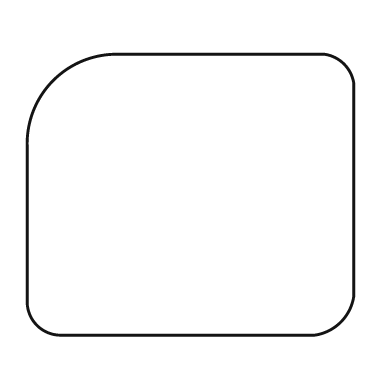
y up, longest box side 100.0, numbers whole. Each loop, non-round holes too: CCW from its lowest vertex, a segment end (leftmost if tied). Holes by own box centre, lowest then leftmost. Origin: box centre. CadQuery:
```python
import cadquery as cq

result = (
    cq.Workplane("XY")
    .moveTo(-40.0, -43.0)
    .lineTo(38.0, -43.0)
    .threePointArc((46.0, -39.0), (50.0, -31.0))
    .lineTo(50.0, 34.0)
    .threePointArc((47.0, 40.0), (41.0, 43.0))
    .lineTo(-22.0, 43.0)
    .threePointArc((-42.0, 35.0), (-50.0, 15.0))
    .lineTo(-50.0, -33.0)
    .threePointArc((-47.0, -40.0), (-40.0, -43.0))
    .close()
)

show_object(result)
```